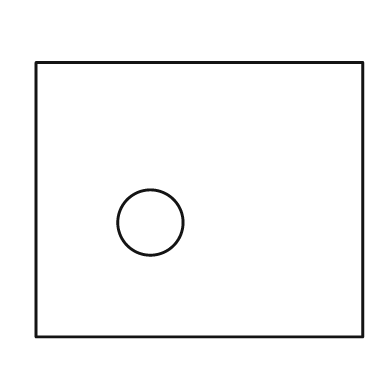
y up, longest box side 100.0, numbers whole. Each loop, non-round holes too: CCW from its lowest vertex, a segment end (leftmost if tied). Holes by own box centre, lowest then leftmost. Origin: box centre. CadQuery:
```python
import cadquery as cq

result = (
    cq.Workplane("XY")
    .moveTo(-50.0, -42.0)
    .lineTo(50.0, -42.0)
    .lineTo(50.0, 42.0)
    .lineTo(-50.0, 42.0)
    .close()
    .moveTo(-15.0, -7.0)
    .circle(10.0)
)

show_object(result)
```